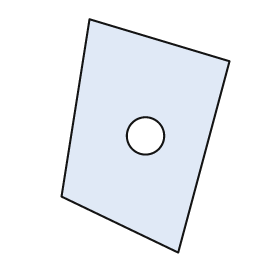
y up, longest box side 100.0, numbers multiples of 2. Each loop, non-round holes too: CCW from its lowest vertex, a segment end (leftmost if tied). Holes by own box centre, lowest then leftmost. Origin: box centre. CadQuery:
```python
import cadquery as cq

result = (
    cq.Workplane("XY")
    .moveTo(14.0, -50.0)
    .lineTo(36.0, 32.0)
    .lineTo(-24.0, 50.0)
    .lineTo(-36.0, -26.0)
    .close()
    .moveTo(0.0, 0.0)
    .circle(8.0)
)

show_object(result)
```